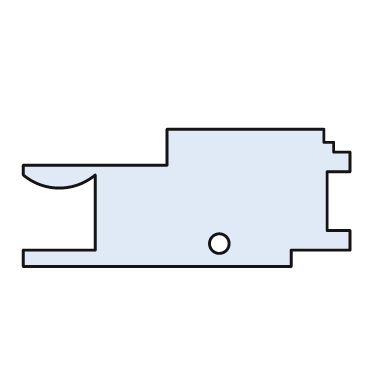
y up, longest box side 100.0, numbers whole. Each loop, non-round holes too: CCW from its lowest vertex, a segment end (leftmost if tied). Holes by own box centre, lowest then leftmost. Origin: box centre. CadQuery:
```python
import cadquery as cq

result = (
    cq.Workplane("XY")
    .moveTo(-50.0, -21.0)
    .lineTo(32.0, -21.0)
    .lineTo(32.0, -16.0)
    .lineTo(50.0, -16.0)
    .lineTo(50.0, -10.0)
    .lineTo(43.0, -10.0)
    .lineTo(43.0, 8.0)
    .lineTo(50.0, 8.0)
    .lineTo(50.0, 14.0)
    .lineTo(45.0, 14.0)
    .lineTo(45.0, 17.0)
    .lineTo(42.0, 17.0)
    .lineTo(42.0, 21.0)
    .lineTo(-6.0, 21.0)
    .lineTo(-6.0, 10.0)
    .lineTo(-50.0, 10.0)
    .lineTo(-50.0, 7.0)
    .threePointArc((-39.0, 3.0), (-28.0, 7.0))
    .lineTo(-28.0, -16.0)
    .lineTo(-50.0, -16.0)
    .close()
    .moveTo(10.0, -14.0)
    .circle(3.0)
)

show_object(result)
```